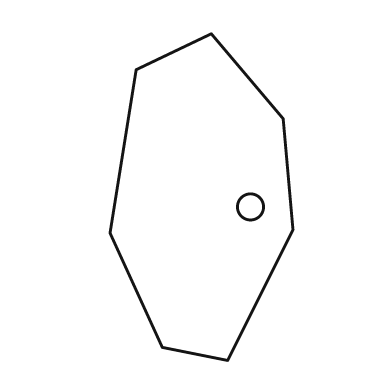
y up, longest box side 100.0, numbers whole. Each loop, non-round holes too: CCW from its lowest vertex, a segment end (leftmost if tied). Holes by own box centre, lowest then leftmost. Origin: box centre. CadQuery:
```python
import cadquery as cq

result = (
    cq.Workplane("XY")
    .moveTo(8.0, -50.0)
    .lineTo(28.0, -10.0)
    .lineTo(25.0, 24.0)
    .lineTo(3.0, 50.0)
    .lineTo(-20.0, 39.0)
    .lineTo(-28.0, -11.0)
    .lineTo(-12.0, -46.0)
    .close()
    .moveTo(15.0, -3.0)
    .circle(4.0)
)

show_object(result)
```